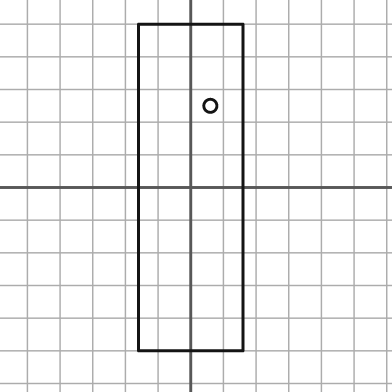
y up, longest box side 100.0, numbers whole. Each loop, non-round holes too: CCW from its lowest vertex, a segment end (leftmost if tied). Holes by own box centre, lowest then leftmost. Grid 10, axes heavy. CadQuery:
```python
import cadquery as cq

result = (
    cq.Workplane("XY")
    .moveTo(-16.0, -50.0)
    .lineTo(16.0, -50.0)
    .lineTo(16.0, 50.0)
    .lineTo(-16.0, 50.0)
    .close()
    .moveTo(6.0, 25.0)
    .circle(2.0)
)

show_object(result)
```